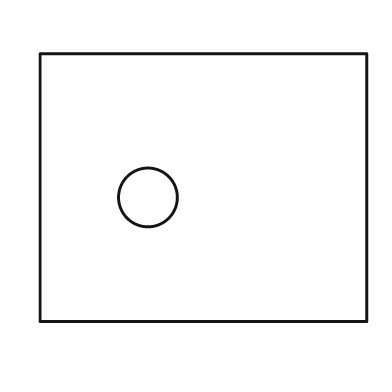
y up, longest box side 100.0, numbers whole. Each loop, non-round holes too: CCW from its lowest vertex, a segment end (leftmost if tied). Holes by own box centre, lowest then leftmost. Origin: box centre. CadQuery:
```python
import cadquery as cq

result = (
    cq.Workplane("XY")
    .moveTo(-50.0, -41.0)
    .lineTo(50.0, -41.0)
    .lineTo(50.0, 41.0)
    .lineTo(-50.0, 41.0)
    .close()
    .moveTo(-17.0, -3.0)
    .circle(9.0)
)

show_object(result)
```